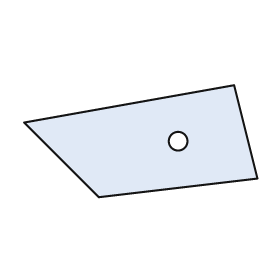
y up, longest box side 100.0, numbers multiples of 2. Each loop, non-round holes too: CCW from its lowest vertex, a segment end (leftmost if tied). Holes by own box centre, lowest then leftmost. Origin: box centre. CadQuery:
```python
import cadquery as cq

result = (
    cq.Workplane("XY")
    .moveTo(-18.0, -24.0)
    .lineTo(50.0, -16.0)
    .lineTo(40.0, 24.0)
    .lineTo(-50.0, 8.0)
    .close()
    .moveTo(16.0, 0.0)
    .circle(4.0)
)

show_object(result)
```